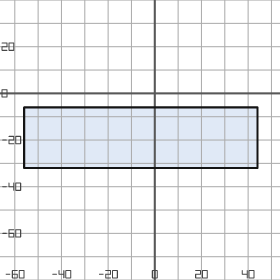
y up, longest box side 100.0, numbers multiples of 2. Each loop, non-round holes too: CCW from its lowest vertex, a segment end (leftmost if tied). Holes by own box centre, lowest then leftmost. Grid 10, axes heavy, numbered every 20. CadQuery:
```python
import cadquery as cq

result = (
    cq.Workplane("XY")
    .moveTo(-56.0, -32.0)
    .lineTo(44.0, -32.0)
    .lineTo(44.0, -6.0)
    .lineTo(-56.0, -6.0)
    .close()
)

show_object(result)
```